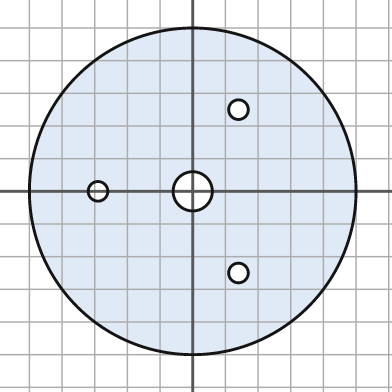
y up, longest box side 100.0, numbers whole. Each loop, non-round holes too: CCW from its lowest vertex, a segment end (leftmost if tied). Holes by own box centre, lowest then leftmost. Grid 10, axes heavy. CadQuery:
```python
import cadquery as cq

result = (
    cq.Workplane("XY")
    .moveTo(0.0, 0.0)
    .circle(50.0)
    .moveTo(14.0, -25.0)
    .circle(3.0)
    .moveTo(-29.0, 0.0)
    .circle(3.0)
    .moveTo(0.0, 0.0)
    .circle(6.0)
    .moveTo(14.0, 25.0)
    .circle(3.0)
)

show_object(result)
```